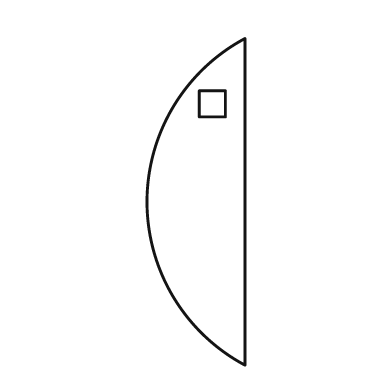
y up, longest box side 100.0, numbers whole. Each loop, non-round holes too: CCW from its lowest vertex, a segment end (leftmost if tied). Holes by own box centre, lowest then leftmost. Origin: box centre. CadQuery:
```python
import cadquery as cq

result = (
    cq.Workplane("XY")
    .moveTo(15.0, -50.0)
    .lineTo(15.0, 50.0)
    .threePointArc((-15.0, 0.0), (15.0, -50.0))
    .close()
    .moveTo(1.0, 26.0)
    .lineTo(9.0, 26.0)
    .lineTo(9.0, 34.0)
    .lineTo(1.0, 34.0)
    .close()
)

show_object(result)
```